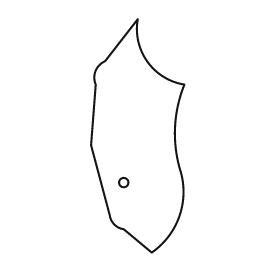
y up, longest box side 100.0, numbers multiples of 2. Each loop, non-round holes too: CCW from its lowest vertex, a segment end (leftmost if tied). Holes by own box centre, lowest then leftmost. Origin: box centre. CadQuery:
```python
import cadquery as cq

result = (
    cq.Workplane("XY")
    .moveTo(6.0, -50.0)
    .threePointArc((18.0, -34.0), (18.0, -14.0))
    .threePointArc((16.0, 4.0), (20.0, 22.0))
    .threePointArc((4.0, 32.0), (0.0, 50.0))
    .lineTo(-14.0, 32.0)
    .threePointArc((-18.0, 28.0), (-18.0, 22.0))
    .lineTo(-20.0, -4.0)
    .lineTo(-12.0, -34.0)
    .threePointArc((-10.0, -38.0), (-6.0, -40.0))
    .close()
    .moveTo(-6.0, -20.0)
    .circle(2.0)
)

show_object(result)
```